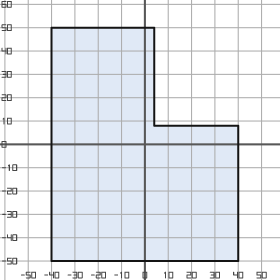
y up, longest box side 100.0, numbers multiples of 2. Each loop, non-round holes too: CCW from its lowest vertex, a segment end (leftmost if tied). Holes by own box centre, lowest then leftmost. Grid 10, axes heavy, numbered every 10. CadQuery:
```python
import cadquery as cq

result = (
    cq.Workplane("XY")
    .moveTo(-40.0, -50.0)
    .lineTo(40.0, -50.0)
    .lineTo(40.0, 8.0)
    .lineTo(4.0, 8.0)
    .lineTo(4.0, 50.0)
    .lineTo(-40.0, 50.0)
    .close()
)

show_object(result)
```